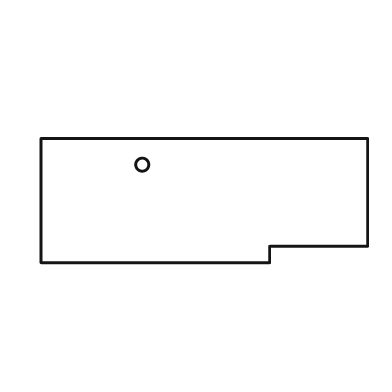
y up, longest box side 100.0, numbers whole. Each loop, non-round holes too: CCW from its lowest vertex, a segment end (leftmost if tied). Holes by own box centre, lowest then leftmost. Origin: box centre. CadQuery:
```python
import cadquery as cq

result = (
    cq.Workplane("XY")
    .moveTo(-50.0, -19.0)
    .lineTo(20.0, -19.0)
    .lineTo(20.0, -14.0)
    .lineTo(50.0, -14.0)
    .lineTo(50.0, 19.0)
    .lineTo(-50.0, 19.0)
    .close()
    .moveTo(-19.0, 11.0)
    .circle(2.0)
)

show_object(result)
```